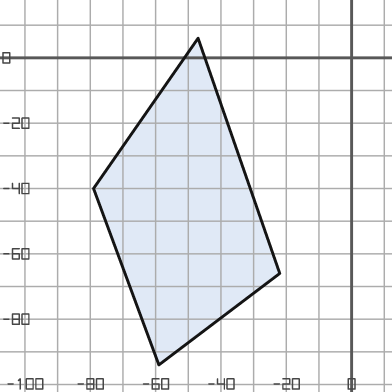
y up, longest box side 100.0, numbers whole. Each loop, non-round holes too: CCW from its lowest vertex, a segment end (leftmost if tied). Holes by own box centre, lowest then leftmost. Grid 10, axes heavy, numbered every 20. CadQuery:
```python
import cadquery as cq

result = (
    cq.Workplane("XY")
    .moveTo(-59.0, -94.0)
    .lineTo(-22.0, -66.0)
    .lineTo(-47.0, 6.0)
    .lineTo(-79.0, -40.0)
    .close()
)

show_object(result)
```